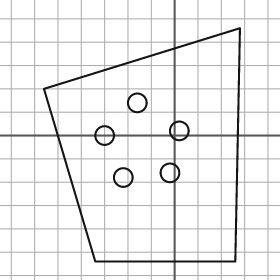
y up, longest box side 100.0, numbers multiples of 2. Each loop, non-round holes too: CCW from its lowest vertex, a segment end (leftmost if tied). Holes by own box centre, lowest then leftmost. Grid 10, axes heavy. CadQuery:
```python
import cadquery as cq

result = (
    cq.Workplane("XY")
    .moveTo(-34.0, -54.0)
    .lineTo(26.0, -54.0)
    .lineTo(28.0, 46.0)
    .lineTo(-56.0, 20.0)
    .close()
    .moveTo(-22.0, -18.0)
    .circle(4.0)
    .moveTo(-2.0, -16.0)
    .circle(4.0)
    .moveTo(-30.0, 0.0)
    .circle(4.0)
    .moveTo(2.0, 2.0)
    .circle(4.0)
    .moveTo(-16.0, 14.0)
    .circle(4.0)
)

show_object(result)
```